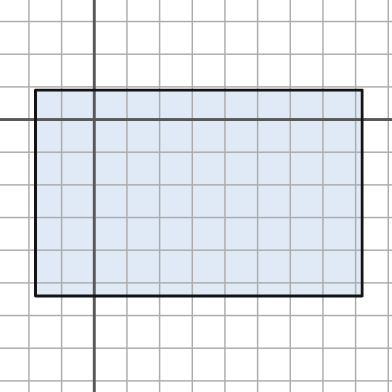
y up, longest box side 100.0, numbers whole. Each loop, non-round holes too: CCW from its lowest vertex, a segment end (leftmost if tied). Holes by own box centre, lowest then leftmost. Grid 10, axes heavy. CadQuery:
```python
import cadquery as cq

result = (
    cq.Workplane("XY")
    .moveTo(-18.0, -54.0)
    .lineTo(82.0, -54.0)
    .lineTo(82.0, 9.0)
    .lineTo(-18.0, 9.0)
    .close()
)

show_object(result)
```